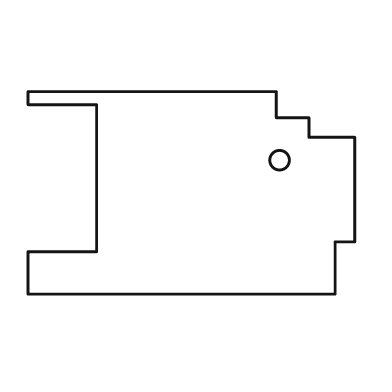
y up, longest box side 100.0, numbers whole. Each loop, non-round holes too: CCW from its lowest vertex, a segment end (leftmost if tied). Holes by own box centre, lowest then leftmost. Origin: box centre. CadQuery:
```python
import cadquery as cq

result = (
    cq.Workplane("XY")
    .moveTo(-50.0, -31.0)
    .lineTo(44.0, -31.0)
    .lineTo(44.0, -15.0)
    .lineTo(50.0, -15.0)
    .lineTo(50.0, 17.0)
    .lineTo(36.0, 17.0)
    .lineTo(36.0, 23.0)
    .lineTo(26.0, 23.0)
    .lineTo(26.0, 31.0)
    .lineTo(-50.0, 31.0)
    .lineTo(-50.0, 27.0)
    .lineTo(-29.0, 27.0)
    .lineTo(-29.0, -18.0)
    .lineTo(-50.0, -18.0)
    .close()
    .moveTo(27.0, 10.0)
    .circle(3.0)
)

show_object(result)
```